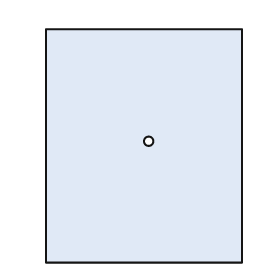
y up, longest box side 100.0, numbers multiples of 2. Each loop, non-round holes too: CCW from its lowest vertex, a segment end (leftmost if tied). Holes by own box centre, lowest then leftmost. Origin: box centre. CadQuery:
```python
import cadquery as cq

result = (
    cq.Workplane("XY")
    .moveTo(-42.0, -50.0)
    .lineTo(42.0, -50.0)
    .lineTo(42.0, 50.0)
    .lineTo(-42.0, 50.0)
    .close()
    .moveTo(2.0, 2.0)
    .circle(2.0)
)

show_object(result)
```